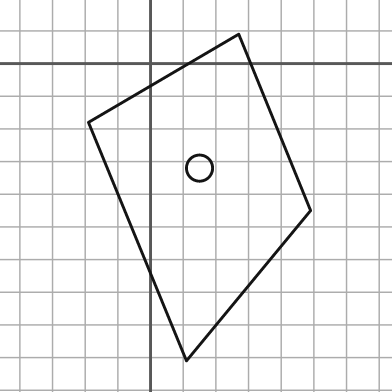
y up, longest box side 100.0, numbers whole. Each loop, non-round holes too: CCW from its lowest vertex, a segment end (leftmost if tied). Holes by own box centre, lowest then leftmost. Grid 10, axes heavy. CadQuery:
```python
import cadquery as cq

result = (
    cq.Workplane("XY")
    .moveTo(11.0, -91.0)
    .lineTo(49.0, -45.0)
    .lineTo(27.0, 9.0)
    .lineTo(-19.0, -18.0)
    .close()
    .moveTo(15.0, -32.0)
    .circle(4.0)
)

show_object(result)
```